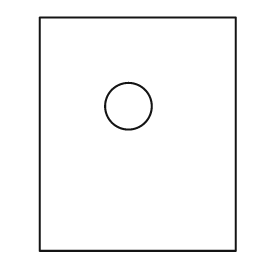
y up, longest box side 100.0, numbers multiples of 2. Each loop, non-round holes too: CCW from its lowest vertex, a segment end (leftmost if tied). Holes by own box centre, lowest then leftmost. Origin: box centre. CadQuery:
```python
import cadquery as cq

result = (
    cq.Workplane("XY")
    .moveTo(-42.0, -50.0)
    .lineTo(42.0, -50.0)
    .lineTo(42.0, 50.0)
    .lineTo(-42.0, 50.0)
    .close()
    .moveTo(-4.0, 12.0)
    .circle(10.0)
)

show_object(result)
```